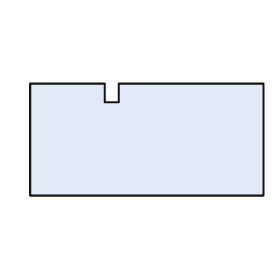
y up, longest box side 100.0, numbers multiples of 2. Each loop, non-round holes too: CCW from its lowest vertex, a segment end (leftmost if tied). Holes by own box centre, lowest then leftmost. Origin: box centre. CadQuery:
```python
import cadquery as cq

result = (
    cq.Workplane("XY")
    .moveTo(-50.0, -24.0)
    .lineTo(50.0, -24.0)
    .lineTo(50.0, 24.0)
    .lineTo(-12.0, 24.0)
    .lineTo(-12.0, 16.0)
    .lineTo(-18.0, 16.0)
    .lineTo(-18.0, 24.0)
    .lineTo(-50.0, 24.0)
    .close()
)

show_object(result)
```